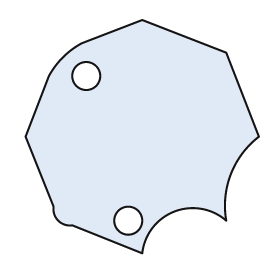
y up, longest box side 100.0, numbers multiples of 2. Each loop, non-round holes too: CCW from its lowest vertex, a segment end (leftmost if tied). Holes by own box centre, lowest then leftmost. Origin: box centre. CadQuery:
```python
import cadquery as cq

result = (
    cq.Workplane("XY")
    .moveTo(0.0, -50.0)
    .threePointArc((14.0, -32.0), (36.0, -36.0))
    .threePointArc((38.0, -16.0), (50.0, 0.0))
    .lineTo(36.0, 36.0)
    .lineTo(0.0, 50.0)
    .lineTo(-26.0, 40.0)
    .threePointArc((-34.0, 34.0), (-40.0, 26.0))
    .lineTo(-50.0, 0.0)
    .lineTo(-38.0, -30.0)
    .threePointArc((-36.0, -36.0), (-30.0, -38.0))
    .close()
    .moveTo(-6.0, -36.0)
    .circle(6.0)
    .moveTo(-24.0, 26.0)
    .circle(6.0)
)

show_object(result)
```